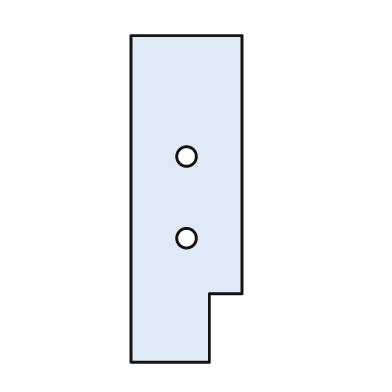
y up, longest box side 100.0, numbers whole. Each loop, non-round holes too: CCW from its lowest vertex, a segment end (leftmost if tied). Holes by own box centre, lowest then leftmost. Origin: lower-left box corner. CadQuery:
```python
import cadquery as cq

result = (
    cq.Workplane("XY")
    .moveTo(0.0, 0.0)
    .lineTo(24.0, 0.0)
    .lineTo(24.0, 21.0)
    .lineTo(34.0, 21.0)
    .lineTo(34.0, 100.0)
    .lineTo(0.0, 100.0)
    .close()
    .moveTo(17.0, 38.0)
    .circle(3.0)
    .moveTo(17.0, 63.0)
    .circle(3.0)
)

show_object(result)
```